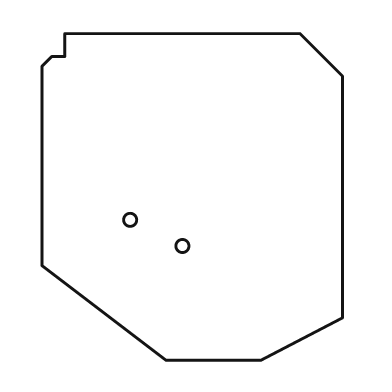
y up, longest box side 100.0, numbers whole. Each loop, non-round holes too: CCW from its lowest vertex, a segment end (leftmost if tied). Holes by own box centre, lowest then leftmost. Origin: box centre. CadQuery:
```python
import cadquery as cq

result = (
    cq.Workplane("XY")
    .moveTo(-8.0, -50.0)
    .lineTo(21.0, -50.0)
    .lineTo(46.0, -37.0)
    .lineTo(46.0, 37.0)
    .lineTo(33.0, 50.0)
    .lineTo(-39.0, 50.0)
    .lineTo(-39.0, 43.0)
    .lineTo(-43.0, 43.0)
    .lineTo(-46.0, 40.0)
    .lineTo(-46.0, -21.0)
    .close()
    .moveTo(-3.0, -15.0)
    .circle(2.0)
    .moveTo(-19.0, -7.0)
    .circle(2.0)
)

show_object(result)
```